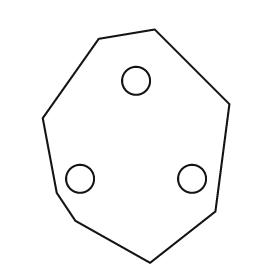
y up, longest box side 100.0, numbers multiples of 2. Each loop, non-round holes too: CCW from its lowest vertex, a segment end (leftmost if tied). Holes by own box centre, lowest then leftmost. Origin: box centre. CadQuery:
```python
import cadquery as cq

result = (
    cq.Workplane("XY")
    .moveTo(6.0, -50.0)
    .lineTo(34.0, -28.0)
    .lineTo(40.0, 18.0)
    .lineTo(8.0, 50.0)
    .lineTo(-16.0, 46.0)
    .lineTo(-40.0, 12.0)
    .lineTo(-34.0, -20.0)
    .lineTo(-26.0, -32.0)
    .close()
    .moveTo(-24.0, -14.0)
    .circle(6.0)
    .moveTo(24.0, -14.0)
    .circle(6.0)
    .moveTo(0.0, 28.0)
    .circle(6.0)
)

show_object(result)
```